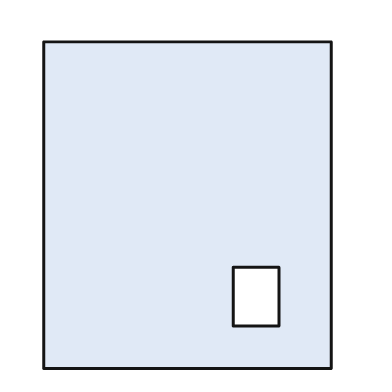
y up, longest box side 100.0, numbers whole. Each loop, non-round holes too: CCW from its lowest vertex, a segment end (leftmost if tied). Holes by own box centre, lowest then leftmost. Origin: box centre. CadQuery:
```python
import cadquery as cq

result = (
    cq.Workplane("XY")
    .moveTo(-44.0, -50.0)
    .lineTo(44.0, -50.0)
    .lineTo(44.0, 50.0)
    .lineTo(-44.0, 50.0)
    .close()
    .moveTo(14.0, -37.0)
    .lineTo(28.0, -37.0)
    .lineTo(28.0, -19.0)
    .lineTo(14.0, -19.0)
    .close()
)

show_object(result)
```